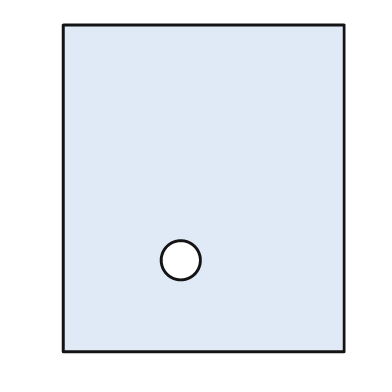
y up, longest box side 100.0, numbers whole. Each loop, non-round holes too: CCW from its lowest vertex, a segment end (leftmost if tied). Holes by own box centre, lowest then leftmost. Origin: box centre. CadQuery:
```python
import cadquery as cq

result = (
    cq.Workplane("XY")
    .moveTo(-43.0, -50.0)
    .lineTo(43.0, -50.0)
    .lineTo(43.0, 50.0)
    .lineTo(-43.0, 50.0)
    .close()
    .moveTo(-7.0, -22.0)
    .circle(6.0)
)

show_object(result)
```